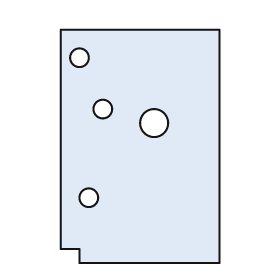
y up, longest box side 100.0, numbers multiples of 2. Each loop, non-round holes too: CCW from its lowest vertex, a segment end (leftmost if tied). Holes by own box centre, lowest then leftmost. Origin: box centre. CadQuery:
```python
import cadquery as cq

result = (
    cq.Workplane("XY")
    .moveTo(-26.0, -50.0)
    .lineTo(34.0, -50.0)
    .lineTo(34.0, 50.0)
    .lineTo(-34.0, 50.0)
    .lineTo(-34.0, -44.0)
    .lineTo(-26.0, -44.0)
    .close()
    .moveTo(-22.0, -22.0)
    .circle(4.0)
    .moveTo(6.0, 10.0)
    .circle(6.0)
    .moveTo(-16.0, 16.0)
    .circle(4.0)
    .moveTo(-26.0, 38.0)
    .circle(4.0)
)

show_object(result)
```